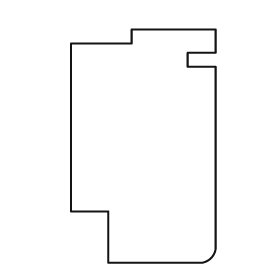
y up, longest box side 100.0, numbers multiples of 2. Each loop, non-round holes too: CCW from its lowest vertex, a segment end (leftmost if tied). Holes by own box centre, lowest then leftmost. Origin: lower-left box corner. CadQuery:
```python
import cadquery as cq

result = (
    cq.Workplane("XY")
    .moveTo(16.0, 0.0)
    .lineTo(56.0, 0.0)
    .threePointArc((60.0, 2.0), (62.0, 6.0))
    .lineTo(62.0, 84.0)
    .lineTo(50.0, 84.0)
    .lineTo(50.0, 90.0)
    .lineTo(62.0, 90.0)
    .lineTo(62.0, 100.0)
    .lineTo(26.0, 100.0)
    .lineTo(26.0, 94.0)
    .lineTo(0.0, 94.0)
    .lineTo(0.0, 22.0)
    .lineTo(16.0, 22.0)
    .close()
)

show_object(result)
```